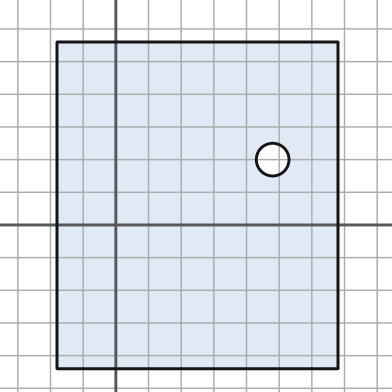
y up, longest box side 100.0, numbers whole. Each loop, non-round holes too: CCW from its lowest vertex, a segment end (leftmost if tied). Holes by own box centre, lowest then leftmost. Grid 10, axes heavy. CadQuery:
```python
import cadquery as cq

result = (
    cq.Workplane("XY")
    .moveTo(-18.0, -44.0)
    .lineTo(68.0, -44.0)
    .lineTo(68.0, 56.0)
    .lineTo(-18.0, 56.0)
    .close()
    .moveTo(48.0, 20.0)
    .circle(5.0)
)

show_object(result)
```